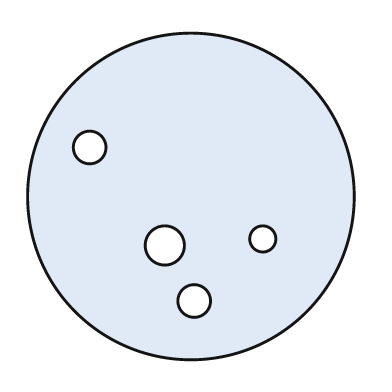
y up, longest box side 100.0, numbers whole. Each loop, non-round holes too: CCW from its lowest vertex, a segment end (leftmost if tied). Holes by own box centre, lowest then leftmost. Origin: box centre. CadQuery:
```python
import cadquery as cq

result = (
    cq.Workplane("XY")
    .moveTo(0.0, 0.0)
    .circle(50.0)
    .moveTo(1.0, -32.0)
    .circle(5.0)
    .moveTo(-8.0, -15.0)
    .circle(6.0)
    .moveTo(22.0, -13.0)
    .circle(4.0)
    .moveTo(-31.0, 15.0)
    .circle(5.0)
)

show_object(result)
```